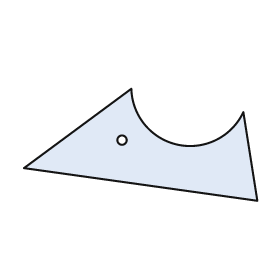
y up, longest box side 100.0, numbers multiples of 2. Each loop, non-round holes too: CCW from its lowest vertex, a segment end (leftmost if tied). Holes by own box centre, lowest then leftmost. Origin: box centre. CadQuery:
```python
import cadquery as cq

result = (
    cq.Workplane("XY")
    .moveTo(50.0, -24.0)
    .lineTo(44.0, 14.0)
    .threePointArc((16.0, 0.0), (-4.0, 24.0))
    .lineTo(-50.0, -10.0)
    .close()
    .moveTo(-8.0, 2.0)
    .circle(2.0)
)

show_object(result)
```